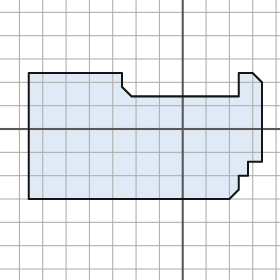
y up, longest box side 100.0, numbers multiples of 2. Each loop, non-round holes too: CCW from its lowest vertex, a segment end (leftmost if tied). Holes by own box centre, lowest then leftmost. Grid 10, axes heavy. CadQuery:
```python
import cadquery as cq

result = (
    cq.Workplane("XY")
    .moveTo(-66.0, -30.0)
    .lineTo(20.0, -30.0)
    .lineTo(24.0, -26.0)
    .lineTo(24.0, -20.0)
    .lineTo(28.0, -20.0)
    .lineTo(28.0, -14.0)
    .lineTo(34.0, -14.0)
    .lineTo(34.0, 20.0)
    .lineTo(30.0, 24.0)
    .lineTo(24.0, 24.0)
    .lineTo(24.0, 14.0)
    .lineTo(-22.0, 14.0)
    .lineTo(-26.0, 18.0)
    .lineTo(-26.0, 24.0)
    .lineTo(-66.0, 24.0)
    .close()
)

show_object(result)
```